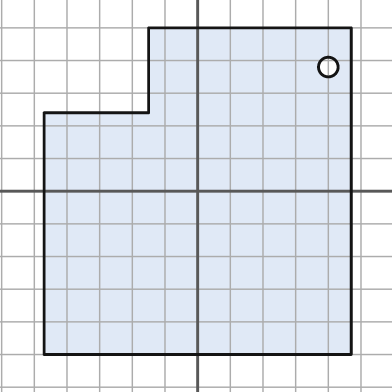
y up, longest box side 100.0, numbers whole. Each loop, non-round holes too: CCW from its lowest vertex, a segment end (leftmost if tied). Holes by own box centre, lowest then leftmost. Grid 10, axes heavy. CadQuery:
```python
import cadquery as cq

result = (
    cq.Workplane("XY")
    .moveTo(-47.0, -50.0)
    .lineTo(47.0, -50.0)
    .lineTo(47.0, 50.0)
    .lineTo(-15.0, 50.0)
    .lineTo(-15.0, 24.0)
    .lineTo(-47.0, 24.0)
    .close()
    .moveTo(40.0, 38.0)
    .circle(3.0)
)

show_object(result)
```